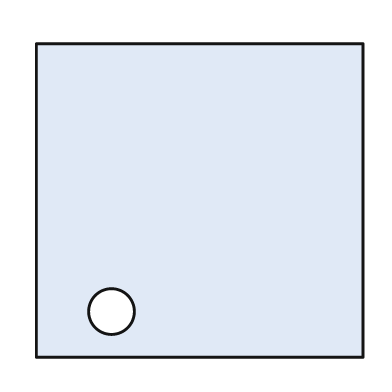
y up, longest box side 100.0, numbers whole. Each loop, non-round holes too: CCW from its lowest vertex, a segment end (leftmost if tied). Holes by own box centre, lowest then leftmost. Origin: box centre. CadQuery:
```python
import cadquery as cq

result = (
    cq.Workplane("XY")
    .moveTo(-50.0, -48.0)
    .lineTo(50.0, -48.0)
    .lineTo(50.0, 48.0)
    .lineTo(-50.0, 48.0)
    .close()
    .moveTo(-27.0, -34.0)
    .circle(7.0)
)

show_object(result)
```